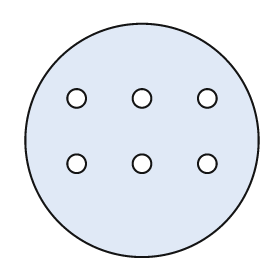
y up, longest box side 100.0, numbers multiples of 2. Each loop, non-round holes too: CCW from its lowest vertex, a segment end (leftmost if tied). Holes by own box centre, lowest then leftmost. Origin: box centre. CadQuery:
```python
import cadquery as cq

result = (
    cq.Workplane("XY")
    .moveTo(0.0, 0.0)
    .circle(50.0)
    .moveTo(-28.0, -10.0)
    .circle(4.0)
    .moveTo(0.0, -10.0)
    .circle(4.0)
    .moveTo(28.0, -10.0)
    .circle(4.0)
    .moveTo(-28.0, 18.0)
    .circle(4.0)
    .moveTo(0.0, 18.0)
    .circle(4.0)
    .moveTo(28.0, 18.0)
    .circle(4.0)
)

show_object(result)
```